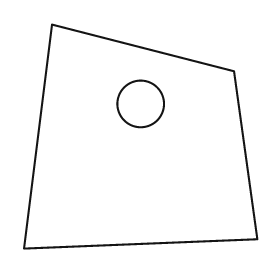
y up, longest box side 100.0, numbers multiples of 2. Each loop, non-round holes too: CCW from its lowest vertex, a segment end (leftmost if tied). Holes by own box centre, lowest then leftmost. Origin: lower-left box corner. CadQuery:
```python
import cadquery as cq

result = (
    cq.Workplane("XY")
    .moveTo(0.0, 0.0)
    .lineTo(100.0, 4.0)
    .lineTo(90.0, 76.0)
    .lineTo(12.0, 96.0)
    .close()
    .moveTo(50.0, 62.0)
    .circle(10.0)
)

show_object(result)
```